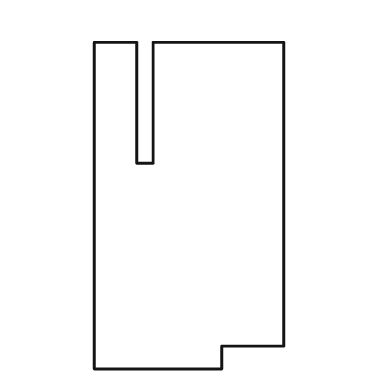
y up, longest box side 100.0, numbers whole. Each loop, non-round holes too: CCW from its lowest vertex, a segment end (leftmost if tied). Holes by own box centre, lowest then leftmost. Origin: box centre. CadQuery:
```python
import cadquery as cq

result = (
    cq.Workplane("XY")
    .moveTo(-29.0, -50.0)
    .lineTo(10.0, -50.0)
    .lineTo(10.0, -43.0)
    .lineTo(29.0, -43.0)
    .lineTo(29.0, 50.0)
    .lineTo(-11.0, 50.0)
    .lineTo(-11.0, 13.0)
    .lineTo(-16.0, 13.0)
    .lineTo(-16.0, 50.0)
    .lineTo(-29.0, 50.0)
    .close()
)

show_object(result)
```